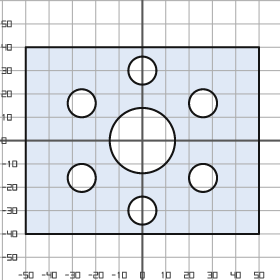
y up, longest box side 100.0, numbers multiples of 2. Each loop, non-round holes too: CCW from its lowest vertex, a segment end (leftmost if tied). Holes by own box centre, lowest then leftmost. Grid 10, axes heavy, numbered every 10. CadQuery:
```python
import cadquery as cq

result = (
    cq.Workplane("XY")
    .moveTo(-50.0, -40.0)
    .lineTo(50.0, -40.0)
    .lineTo(50.0, 40.0)
    .lineTo(-50.0, 40.0)
    .close()
    .moveTo(0.0, -30.0)
    .circle(6.0)
    .moveTo(-26.0, -16.0)
    .circle(6.0)
    .moveTo(26.0, -16.0)
    .circle(6.0)
    .moveTo(0.0, 0.0)
    .circle(14.0)
    .moveTo(-26.0, 16.0)
    .circle(6.0)
    .moveTo(26.0, 16.0)
    .circle(6.0)
    .moveTo(0.0, 30.0)
    .circle(6.0)
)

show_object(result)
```